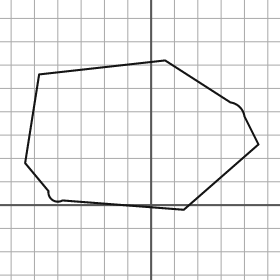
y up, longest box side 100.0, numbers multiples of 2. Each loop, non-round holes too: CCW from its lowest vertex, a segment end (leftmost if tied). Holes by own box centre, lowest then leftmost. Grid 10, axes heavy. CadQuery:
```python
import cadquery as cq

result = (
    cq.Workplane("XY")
    .moveTo(14.0, -2.0)
    .lineTo(46.0, 26.0)
    .lineTo(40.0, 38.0)
    .threePointArc((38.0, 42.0), (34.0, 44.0))
    .lineTo(6.0, 62.0)
    .lineTo(-48.0, 56.0)
    .lineTo(-54.0, 18.0)
    .lineTo(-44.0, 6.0)
    .threePointArc((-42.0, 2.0), (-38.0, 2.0))
    .close()
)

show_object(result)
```